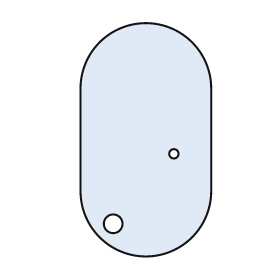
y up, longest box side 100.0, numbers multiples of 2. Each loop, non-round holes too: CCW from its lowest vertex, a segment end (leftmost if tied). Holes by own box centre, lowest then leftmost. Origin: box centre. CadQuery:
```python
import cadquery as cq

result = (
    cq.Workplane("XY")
    .moveTo(-28.0, -22.0)
    .threePointArc((0.0, -50.0), (28.0, -22.0))
    .lineTo(28.0, 22.0)
    .threePointArc((0.0, 50.0), (-28.0, 22.0))
    .close()
    .moveTo(-14.0, -36.0)
    .circle(4.0)
    .moveTo(12.0, -6.0)
    .circle(2.0)
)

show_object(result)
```